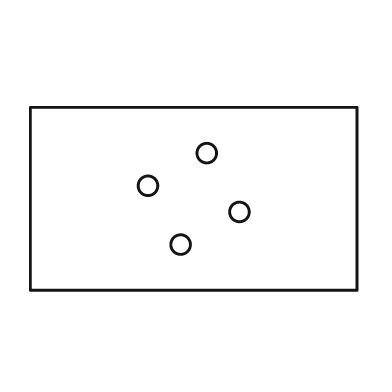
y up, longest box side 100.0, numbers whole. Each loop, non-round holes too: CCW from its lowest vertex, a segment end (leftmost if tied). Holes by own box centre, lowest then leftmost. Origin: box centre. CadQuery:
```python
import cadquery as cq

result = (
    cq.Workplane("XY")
    .moveTo(-50.0, -28.0)
    .lineTo(50.0, -28.0)
    .lineTo(50.0, 28.0)
    .lineTo(-50.0, 28.0)
    .close()
    .moveTo(-4.0, -14.0)
    .circle(3.0)
    .moveTo(14.0, -4.0)
    .circle(3.0)
    .moveTo(-14.0, 4.0)
    .circle(3.0)
    .moveTo(4.0, 14.0)
    .circle(3.0)
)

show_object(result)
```